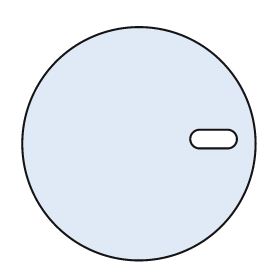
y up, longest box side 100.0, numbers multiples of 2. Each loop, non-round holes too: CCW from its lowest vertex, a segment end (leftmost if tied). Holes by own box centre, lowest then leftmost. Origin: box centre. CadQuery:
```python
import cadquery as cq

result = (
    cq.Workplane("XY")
    .moveTo(0.0, 0.0)
    .circle(50.0)
    .moveTo(26.0, -2.0)
    .lineTo(38.0, -2.0)
    .threePointArc((42.0, 2.0), (38.0, 6.0))
    .lineTo(26.0, 6.0)
    .threePointArc((22.0, 2.0), (26.0, -2.0))
    .close()
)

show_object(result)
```